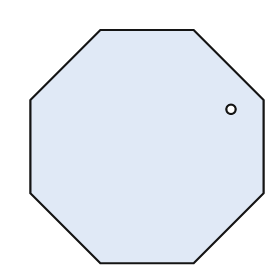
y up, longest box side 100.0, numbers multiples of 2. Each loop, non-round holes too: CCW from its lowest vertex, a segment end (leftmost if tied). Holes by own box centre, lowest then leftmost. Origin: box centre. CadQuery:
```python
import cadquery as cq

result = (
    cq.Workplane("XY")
    .moveTo(-20.0, -50.0)
    .lineTo(20.0, -50.0)
    .lineTo(50.0, -20.0)
    .lineTo(50.0, 20.0)
    .lineTo(20.0, 50.0)
    .lineTo(-20.0, 50.0)
    .lineTo(-50.0, 20.0)
    .lineTo(-50.0, -20.0)
    .close()
    .moveTo(36.0, 16.0)
    .circle(2.0)
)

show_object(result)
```